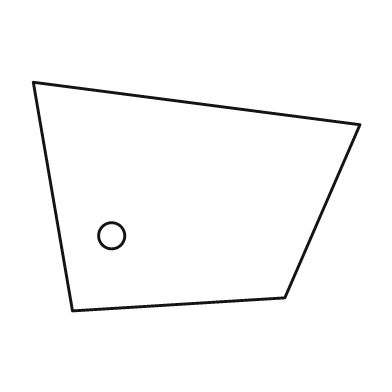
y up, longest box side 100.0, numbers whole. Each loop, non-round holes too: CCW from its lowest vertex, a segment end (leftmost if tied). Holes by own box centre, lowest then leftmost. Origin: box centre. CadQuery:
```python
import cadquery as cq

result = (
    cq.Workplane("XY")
    .moveTo(-38.0, -35.0)
    .lineTo(27.0, -31.0)
    .lineTo(50.0, 22.0)
    .lineTo(-50.0, 35.0)
    .close()
    .moveTo(-26.0, -12.0)
    .circle(4.0)
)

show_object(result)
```